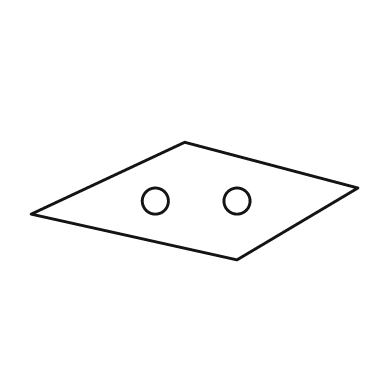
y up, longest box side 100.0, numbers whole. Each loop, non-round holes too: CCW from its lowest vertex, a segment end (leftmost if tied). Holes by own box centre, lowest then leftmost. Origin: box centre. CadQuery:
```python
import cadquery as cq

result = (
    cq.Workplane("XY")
    .moveTo(13.0, -18.0)
    .lineTo(50.0, 4.0)
    .lineTo(-3.0, 18.0)
    .lineTo(-50.0, -4.0)
    .close()
    .moveTo(-12.0, 0.0)
    .circle(4.0)
    .moveTo(13.0, 0.0)
    .circle(4.0)
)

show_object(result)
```